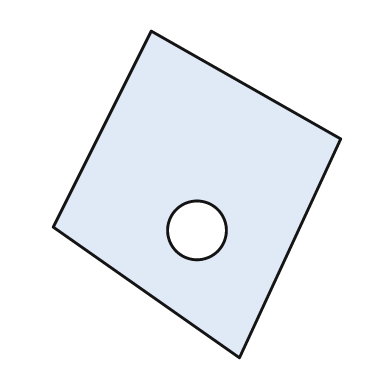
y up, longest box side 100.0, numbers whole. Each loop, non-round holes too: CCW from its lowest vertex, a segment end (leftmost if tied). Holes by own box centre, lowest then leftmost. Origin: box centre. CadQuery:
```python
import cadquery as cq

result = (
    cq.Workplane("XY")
    .moveTo(13.0, -50.0)
    .lineTo(44.0, 17.0)
    .lineTo(-14.0, 50.0)
    .lineTo(-44.0, -10.0)
    .close()
    .moveTo(0.0, -11.0)
    .circle(9.0)
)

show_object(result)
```